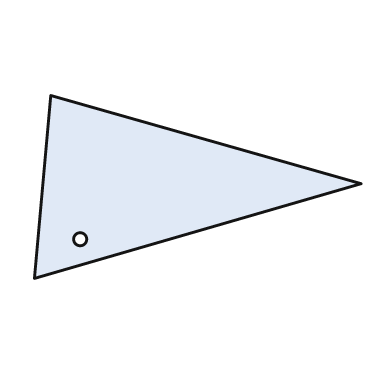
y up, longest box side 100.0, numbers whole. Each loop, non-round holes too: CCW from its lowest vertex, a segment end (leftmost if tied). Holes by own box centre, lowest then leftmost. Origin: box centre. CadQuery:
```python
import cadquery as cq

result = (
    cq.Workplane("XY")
    .moveTo(-50.0, -28.0)
    .lineTo(50.0, 1.0)
    .lineTo(-45.0, 28.0)
    .close()
    .moveTo(-36.0, -16.0)
    .circle(2.0)
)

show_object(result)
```